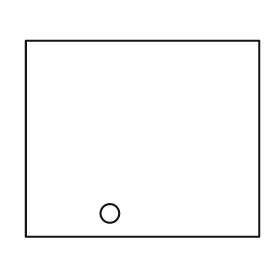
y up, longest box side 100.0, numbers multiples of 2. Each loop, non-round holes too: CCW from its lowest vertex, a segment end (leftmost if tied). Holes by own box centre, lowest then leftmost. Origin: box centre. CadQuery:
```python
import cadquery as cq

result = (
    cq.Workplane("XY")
    .moveTo(-50.0, -42.0)
    .lineTo(50.0, -42.0)
    .lineTo(50.0, 42.0)
    .lineTo(-50.0, 42.0)
    .close()
    .moveTo(-14.0, -32.0)
    .circle(4.0)
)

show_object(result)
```